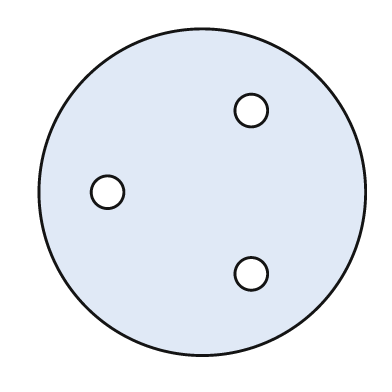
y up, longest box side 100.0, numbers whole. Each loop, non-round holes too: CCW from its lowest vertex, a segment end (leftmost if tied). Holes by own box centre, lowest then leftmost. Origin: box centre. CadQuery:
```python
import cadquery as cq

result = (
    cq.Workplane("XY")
    .moveTo(0.0, 0.0)
    .circle(50.0)
    .moveTo(15.0, -25.0)
    .circle(5.0)
    .moveTo(-29.0, 0.0)
    .circle(5.0)
    .moveTo(15.0, 25.0)
    .circle(5.0)
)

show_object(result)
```